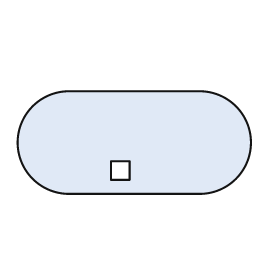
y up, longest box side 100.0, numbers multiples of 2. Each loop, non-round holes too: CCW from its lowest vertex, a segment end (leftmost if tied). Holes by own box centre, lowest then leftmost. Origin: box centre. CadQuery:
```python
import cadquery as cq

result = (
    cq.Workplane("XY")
    .moveTo(-28.0, -22.0)
    .lineTo(28.0, -22.0)
    .threePointArc((50.0, 0.0), (28.0, 22.0))
    .lineTo(-28.0, 22.0)
    .threePointArc((-50.0, 0.0), (-28.0, -22.0))
    .close()
    .moveTo(-10.0, -16.0)
    .lineTo(-2.0, -16.0)
    .lineTo(-2.0, -8.0)
    .lineTo(-10.0, -8.0)
    .close()
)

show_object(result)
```